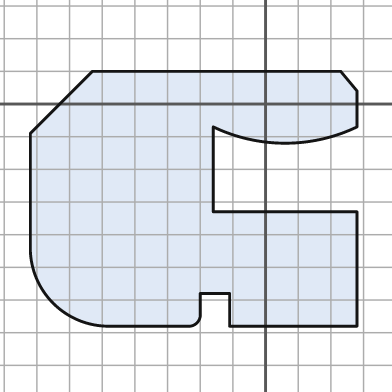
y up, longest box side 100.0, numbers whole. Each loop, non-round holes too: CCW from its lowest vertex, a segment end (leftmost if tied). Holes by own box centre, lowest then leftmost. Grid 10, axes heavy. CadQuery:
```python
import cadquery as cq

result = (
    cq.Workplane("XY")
    .moveTo(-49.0, -68.0)
    .lineTo(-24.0, -68.0)
    .threePointArc((-21.0, -67.0), (-20.0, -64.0))
    .lineTo(-20.0, -58.0)
    .lineTo(-11.0, -58.0)
    .lineTo(-11.0, -68.0)
    .lineTo(28.0, -68.0)
    .lineTo(28.0, -33.0)
    .lineTo(-16.0, -33.0)
    .lineTo(-16.0, -7.0)
    .threePointArc((6.0, -12.0), (28.0, -7.0))
    .lineTo(28.0, 4.0)
    .lineTo(23.0, 10.0)
    .lineTo(-53.0, 10.0)
    .lineTo(-72.0, -9.0)
    .lineTo(-72.0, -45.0)
    .threePointArc((-65.0, -61.0), (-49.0, -68.0))
    .close()
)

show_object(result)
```